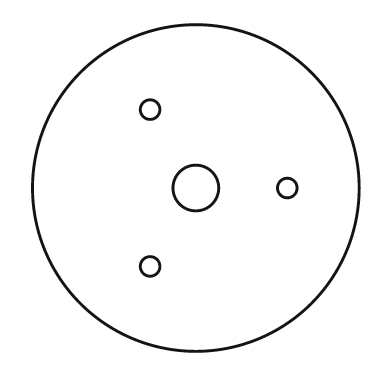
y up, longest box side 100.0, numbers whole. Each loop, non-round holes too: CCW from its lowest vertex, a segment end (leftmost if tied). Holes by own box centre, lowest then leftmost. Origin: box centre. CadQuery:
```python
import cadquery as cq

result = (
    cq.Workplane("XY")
    .moveTo(0.0, 0.0)
    .circle(50.0)
    .moveTo(-14.0, -24.0)
    .circle(3.0)
    .moveTo(0.0, 0.0)
    .circle(7.0)
    .moveTo(28.0, 0.0)
    .circle(3.0)
    .moveTo(-14.0, 24.0)
    .circle(3.0)
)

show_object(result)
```